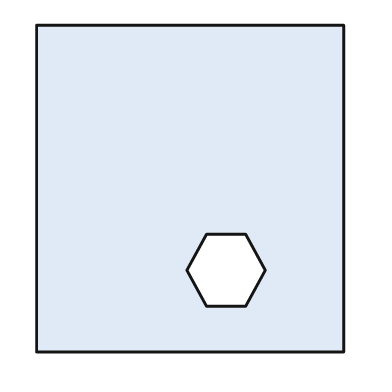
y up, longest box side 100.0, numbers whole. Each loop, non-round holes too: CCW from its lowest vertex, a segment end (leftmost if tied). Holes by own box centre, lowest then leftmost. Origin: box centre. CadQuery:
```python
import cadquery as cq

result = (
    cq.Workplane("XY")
    .moveTo(-47.0, -50.0)
    .lineTo(47.0, -50.0)
    .lineTo(47.0, 50.0)
    .lineTo(-47.0, 50.0)
    .close()
    .moveTo(5.0, -36.0)
    .lineTo(17.0, -36.0)
    .lineTo(23.0, -25.0)
    .lineTo(17.0, -14.0)
    .lineTo(5.0, -14.0)
    .lineTo(-1.0, -25.0)
    .close()
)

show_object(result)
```